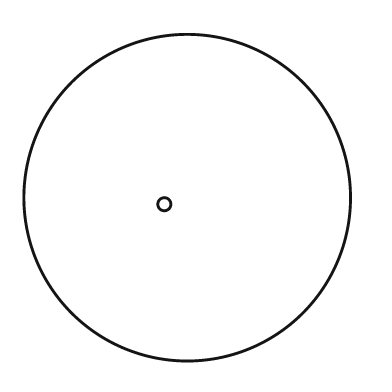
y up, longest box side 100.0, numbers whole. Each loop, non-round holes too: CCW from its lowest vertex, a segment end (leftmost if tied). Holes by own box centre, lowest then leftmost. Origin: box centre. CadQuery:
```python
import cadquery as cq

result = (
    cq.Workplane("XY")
    .moveTo(0.0, 0.0)
    .circle(50.0)
    .moveTo(-7.0, -2.0)
    .circle(2.0)
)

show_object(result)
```